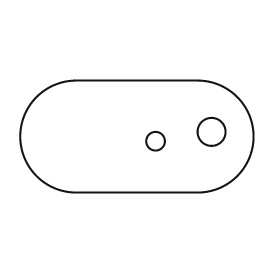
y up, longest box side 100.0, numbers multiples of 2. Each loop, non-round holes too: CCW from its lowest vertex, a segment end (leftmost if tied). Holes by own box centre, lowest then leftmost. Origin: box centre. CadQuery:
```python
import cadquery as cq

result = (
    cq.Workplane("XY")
    .moveTo(-26.0, -24.0)
    .lineTo(26.0, -24.0)
    .threePointArc((50.0, 0.0), (26.0, 24.0))
    .lineTo(-26.0, 24.0)
    .threePointArc((-50.0, 0.0), (-26.0, -24.0))
    .close()
    .moveTo(8.0, -2.0)
    .circle(4.0)
    .moveTo(32.0, 2.0)
    .circle(6.0)
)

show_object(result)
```